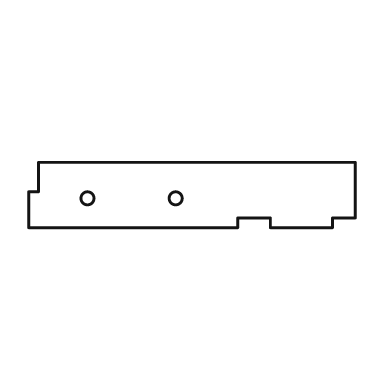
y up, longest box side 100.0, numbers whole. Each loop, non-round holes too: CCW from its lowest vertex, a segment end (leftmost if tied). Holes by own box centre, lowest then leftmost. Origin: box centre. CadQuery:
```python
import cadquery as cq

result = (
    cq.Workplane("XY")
    .moveTo(-50.0, -10.0)
    .lineTo(14.0, -10.0)
    .lineTo(14.0, -7.0)
    .lineTo(24.0, -7.0)
    .lineTo(24.0, -10.0)
    .lineTo(43.0, -10.0)
    .lineTo(43.0, -7.0)
    .lineTo(50.0, -7.0)
    .lineTo(50.0, 10.0)
    .lineTo(-47.0, 10.0)
    .lineTo(-47.0, 1.0)
    .lineTo(-50.0, 1.0)
    .close()
    .moveTo(-32.0, -1.0)
    .circle(2.0)
    .moveTo(-5.0, -1.0)
    .circle(2.0)
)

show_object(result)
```